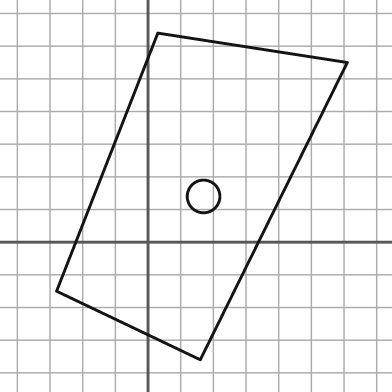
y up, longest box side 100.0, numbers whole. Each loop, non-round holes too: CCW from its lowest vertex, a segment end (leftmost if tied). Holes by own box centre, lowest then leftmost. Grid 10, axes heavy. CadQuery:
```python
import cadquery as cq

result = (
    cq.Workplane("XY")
    .moveTo(16.0, -36.0)
    .lineTo(61.0, 55.0)
    .lineTo(3.0, 64.0)
    .lineTo(-28.0, -15.0)
    .close()
    .moveTo(17.0, 14.0)
    .circle(5.0)
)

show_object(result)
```